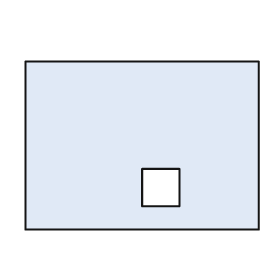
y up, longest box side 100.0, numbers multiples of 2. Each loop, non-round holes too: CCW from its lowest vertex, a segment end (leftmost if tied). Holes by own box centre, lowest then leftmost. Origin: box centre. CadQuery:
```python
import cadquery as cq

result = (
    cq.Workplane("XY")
    .moveTo(-50.0, -36.0)
    .lineTo(50.0, -36.0)
    .lineTo(50.0, 36.0)
    .lineTo(-50.0, 36.0)
    .close()
    .moveTo(0.0, -26.0)
    .lineTo(16.0, -26.0)
    .lineTo(16.0, -10.0)
    .lineTo(0.0, -10.0)
    .close()
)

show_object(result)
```